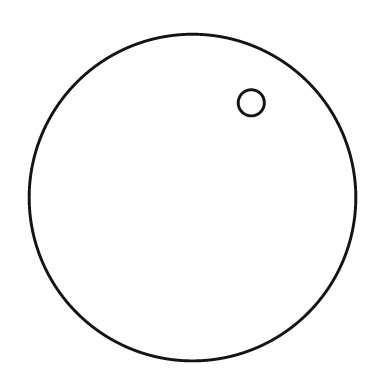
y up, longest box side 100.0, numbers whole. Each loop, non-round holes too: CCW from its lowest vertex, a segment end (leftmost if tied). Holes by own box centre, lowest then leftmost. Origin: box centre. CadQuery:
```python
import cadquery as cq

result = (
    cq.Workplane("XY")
    .moveTo(0.0, 0.0)
    .circle(50.0)
    .moveTo(18.0, 29.0)
    .circle(4.0)
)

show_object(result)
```